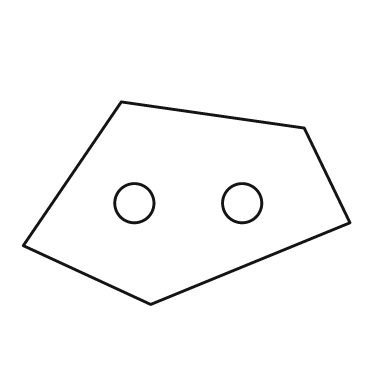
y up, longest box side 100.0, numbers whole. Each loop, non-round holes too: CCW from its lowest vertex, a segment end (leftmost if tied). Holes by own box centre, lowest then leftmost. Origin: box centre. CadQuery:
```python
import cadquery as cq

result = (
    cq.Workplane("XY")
    .moveTo(-11.0, -31.0)
    .lineTo(50.0, -6.0)
    .lineTo(36.0, 23.0)
    .lineTo(-20.0, 31.0)
    .lineTo(-50.0, -13.0)
    .close()
    .moveTo(-16.0, 0.0)
    .circle(6.0)
    .moveTo(17.0, 0.0)
    .circle(6.0)
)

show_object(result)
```